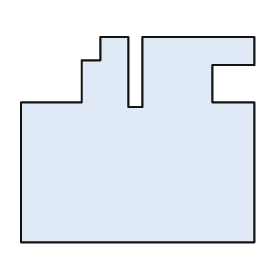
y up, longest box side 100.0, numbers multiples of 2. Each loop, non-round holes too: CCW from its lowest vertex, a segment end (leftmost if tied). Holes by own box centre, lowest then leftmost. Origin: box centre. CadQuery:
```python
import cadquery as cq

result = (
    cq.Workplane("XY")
    .moveTo(-50.0, -44.0)
    .lineTo(50.0, -44.0)
    .lineTo(50.0, 16.0)
    .lineTo(32.0, 16.0)
    .lineTo(32.0, 32.0)
    .lineTo(50.0, 32.0)
    .lineTo(50.0, 44.0)
    .lineTo(2.0, 44.0)
    .lineTo(2.0, 14.0)
    .lineTo(-4.0, 14.0)
    .lineTo(-4.0, 44.0)
    .lineTo(-16.0, 44.0)
    .lineTo(-16.0, 34.0)
    .lineTo(-24.0, 34.0)
    .lineTo(-24.0, 16.0)
    .lineTo(-50.0, 16.0)
    .close()
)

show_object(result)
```